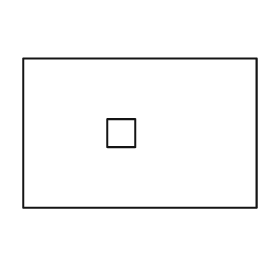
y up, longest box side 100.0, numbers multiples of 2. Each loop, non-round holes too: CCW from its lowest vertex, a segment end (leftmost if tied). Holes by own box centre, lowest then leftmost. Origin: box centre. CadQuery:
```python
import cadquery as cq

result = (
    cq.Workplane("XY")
    .moveTo(-50.0, -32.0)
    .lineTo(50.0, -32.0)
    .lineTo(50.0, 32.0)
    .lineTo(-50.0, 32.0)
    .close()
    .moveTo(-14.0, -6.0)
    .lineTo(-2.0, -6.0)
    .lineTo(-2.0, 6.0)
    .lineTo(-14.0, 6.0)
    .close()
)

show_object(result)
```